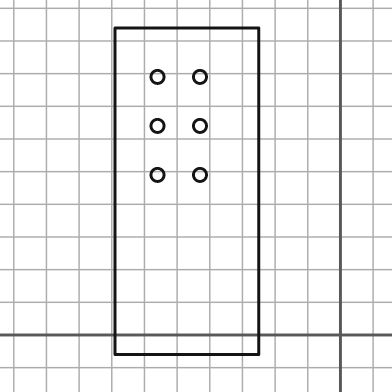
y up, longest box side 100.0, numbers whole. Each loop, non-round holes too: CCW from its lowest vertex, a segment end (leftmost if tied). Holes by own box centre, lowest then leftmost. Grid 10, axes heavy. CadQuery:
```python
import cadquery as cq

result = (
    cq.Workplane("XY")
    .moveTo(-69.0, -6.0)
    .lineTo(-25.0, -6.0)
    .lineTo(-25.0, 94.0)
    .lineTo(-69.0, 94.0)
    .close()
    .moveTo(-56.0, 49.0)
    .circle(2.0)
    .moveTo(-43.0, 49.0)
    .circle(2.0)
    .moveTo(-56.0, 64.0)
    .circle(2.0)
    .moveTo(-43.0, 64.0)
    .circle(2.0)
    .moveTo(-56.0, 79.0)
    .circle(2.0)
    .moveTo(-43.0, 79.0)
    .circle(2.0)
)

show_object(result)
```